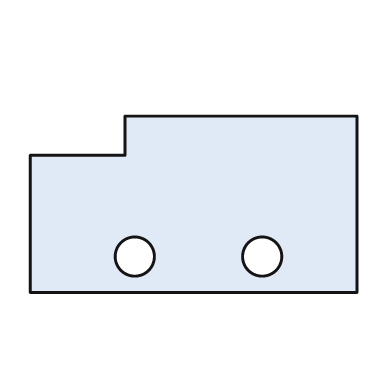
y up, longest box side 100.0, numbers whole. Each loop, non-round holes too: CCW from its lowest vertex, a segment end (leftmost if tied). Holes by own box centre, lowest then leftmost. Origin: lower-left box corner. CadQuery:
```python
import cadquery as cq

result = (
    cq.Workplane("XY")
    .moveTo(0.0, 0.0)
    .lineTo(100.0, 0.0)
    .lineTo(100.0, 54.0)
    .lineTo(29.0, 54.0)
    .lineTo(29.0, 42.0)
    .lineTo(0.0, 42.0)
    .close()
    .moveTo(32.0, 11.0)
    .circle(6.0)
    .moveTo(71.0, 11.0)
    .circle(6.0)
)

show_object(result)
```